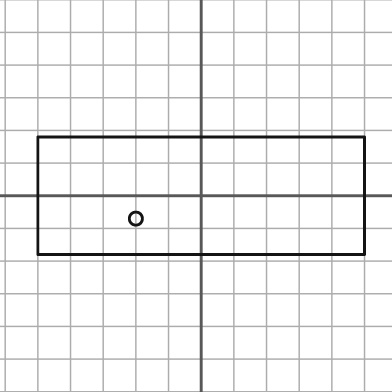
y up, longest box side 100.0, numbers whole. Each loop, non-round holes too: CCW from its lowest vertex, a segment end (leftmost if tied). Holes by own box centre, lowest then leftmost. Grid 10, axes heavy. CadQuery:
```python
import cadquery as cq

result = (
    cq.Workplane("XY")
    .moveTo(-50.0, -18.0)
    .lineTo(50.0, -18.0)
    .lineTo(50.0, 18.0)
    .lineTo(-50.0, 18.0)
    .close()
    .moveTo(-20.0, -7.0)
    .circle(2.0)
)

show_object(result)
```